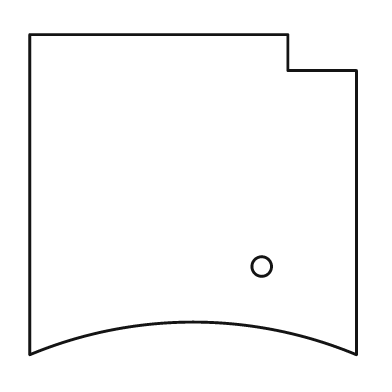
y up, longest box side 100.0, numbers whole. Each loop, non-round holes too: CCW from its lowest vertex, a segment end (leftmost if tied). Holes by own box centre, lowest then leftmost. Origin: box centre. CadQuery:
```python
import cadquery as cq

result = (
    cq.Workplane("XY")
    .moveTo(-50.0, -49.0)
    .threePointArc((0.0, -39.0), (50.0, -49.0))
    .lineTo(50.0, 38.0)
    .lineTo(29.0, 38.0)
    .lineTo(29.0, 49.0)
    .lineTo(-50.0, 49.0)
    .close()
    .moveTo(21.0, -22.0)
    .circle(3.0)
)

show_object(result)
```